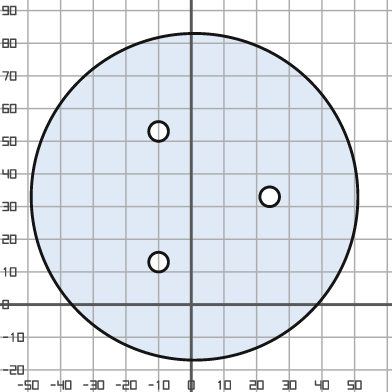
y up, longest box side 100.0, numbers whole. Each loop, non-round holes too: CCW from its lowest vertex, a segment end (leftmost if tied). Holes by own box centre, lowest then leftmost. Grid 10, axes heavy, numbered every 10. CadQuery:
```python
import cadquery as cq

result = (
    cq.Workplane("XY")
    .moveTo(1.0, 33.0)
    .circle(50.0)
    .moveTo(-10.0, 13.0)
    .circle(3.0)
    .moveTo(24.0, 33.0)
    .circle(3.0)
    .moveTo(-10.0, 53.0)
    .circle(3.0)
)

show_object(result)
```